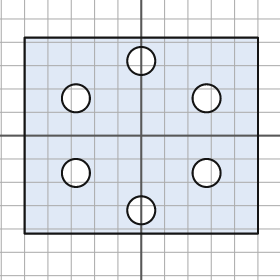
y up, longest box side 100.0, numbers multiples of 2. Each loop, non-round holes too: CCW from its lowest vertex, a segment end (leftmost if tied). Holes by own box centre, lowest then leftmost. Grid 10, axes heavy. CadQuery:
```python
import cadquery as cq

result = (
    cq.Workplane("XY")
    .moveTo(-50.0, -42.0)
    .lineTo(50.0, -42.0)
    .lineTo(50.0, 42.0)
    .lineTo(-50.0, 42.0)
    .close()
    .moveTo(0.0, -32.0)
    .circle(6.0)
    .moveTo(-28.0, -16.0)
    .circle(6.0)
    .moveTo(28.0, -16.0)
    .circle(6.0)
    .moveTo(-28.0, 16.0)
    .circle(6.0)
    .moveTo(28.0, 16.0)
    .circle(6.0)
    .moveTo(0.0, 32.0)
    .circle(6.0)
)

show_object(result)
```